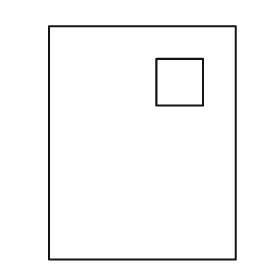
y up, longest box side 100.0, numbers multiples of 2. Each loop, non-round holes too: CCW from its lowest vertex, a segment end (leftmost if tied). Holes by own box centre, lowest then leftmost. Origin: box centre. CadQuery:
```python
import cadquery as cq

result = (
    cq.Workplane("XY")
    .moveTo(-40.0, -50.0)
    .lineTo(40.0, -50.0)
    .lineTo(40.0, 50.0)
    .lineTo(-40.0, 50.0)
    .close()
    .moveTo(6.0, 16.0)
    .lineTo(26.0, 16.0)
    .lineTo(26.0, 36.0)
    .lineTo(6.0, 36.0)
    .close()
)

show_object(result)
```